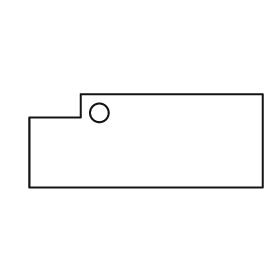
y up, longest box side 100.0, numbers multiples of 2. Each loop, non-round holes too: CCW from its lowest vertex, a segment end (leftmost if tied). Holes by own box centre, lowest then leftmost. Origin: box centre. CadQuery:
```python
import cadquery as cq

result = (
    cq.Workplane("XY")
    .moveTo(-50.0, -20.0)
    .lineTo(50.0, -20.0)
    .lineTo(50.0, 20.0)
    .lineTo(-28.0, 20.0)
    .lineTo(-28.0, 10.0)
    .lineTo(-50.0, 10.0)
    .close()
    .moveTo(-20.0, 12.0)
    .circle(4.0)
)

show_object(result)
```